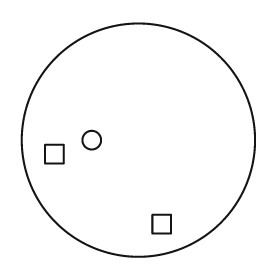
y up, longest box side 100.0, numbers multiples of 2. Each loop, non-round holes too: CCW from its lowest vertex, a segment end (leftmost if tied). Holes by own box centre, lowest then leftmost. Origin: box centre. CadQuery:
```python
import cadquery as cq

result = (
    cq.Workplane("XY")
    .moveTo(0.0, 0.0)
    .circle(50.0)
    .moveTo(6.0, -40.0)
    .lineTo(14.0, -40.0)
    .lineTo(14.0, -32.0)
    .lineTo(6.0, -32.0)
    .close()
    .moveTo(-40.0, -10.0)
    .lineTo(-32.0, -10.0)
    .lineTo(-32.0, -2.0)
    .lineTo(-40.0, -2.0)
    .close()
    .moveTo(-20.0, 0.0)
    .circle(4.0)
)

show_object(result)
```